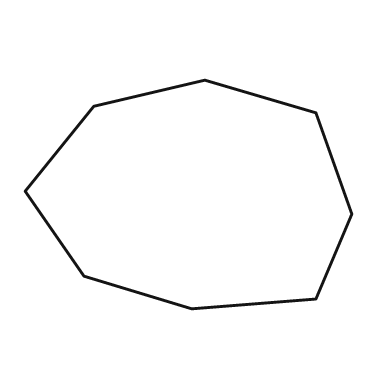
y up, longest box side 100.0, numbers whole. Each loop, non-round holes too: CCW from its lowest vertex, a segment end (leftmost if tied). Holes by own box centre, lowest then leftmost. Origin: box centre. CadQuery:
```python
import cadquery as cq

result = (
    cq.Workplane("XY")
    .moveTo(1.0, -35.0)
    .lineTo(39.0, -32.0)
    .lineTo(50.0, -6.0)
    .lineTo(39.0, 25.0)
    .lineTo(5.0, 35.0)
    .lineTo(-29.0, 27.0)
    .lineTo(-50.0, 1.0)
    .lineTo(-32.0, -25.0)
    .close()
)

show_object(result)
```